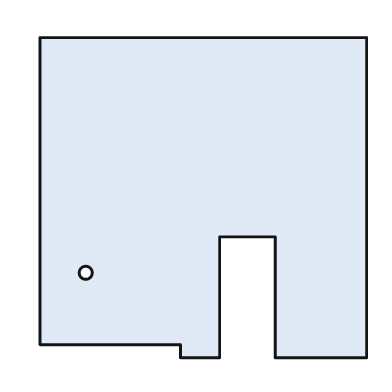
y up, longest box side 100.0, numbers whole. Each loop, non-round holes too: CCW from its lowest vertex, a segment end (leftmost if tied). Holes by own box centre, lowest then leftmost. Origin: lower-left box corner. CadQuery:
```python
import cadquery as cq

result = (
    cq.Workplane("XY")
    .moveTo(43.0, 0.0)
    .lineTo(55.0, 0.0)
    .lineTo(55.0, 37.0)
    .lineTo(72.0, 37.0)
    .lineTo(72.0, 0.0)
    .lineTo(100.0, 0.0)
    .lineTo(100.0, 98.0)
    .lineTo(0.0, 98.0)
    .lineTo(0.0, 4.0)
    .lineTo(43.0, 4.0)
    .close()
    .moveTo(14.0, 26.0)
    .circle(2.0)
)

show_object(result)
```